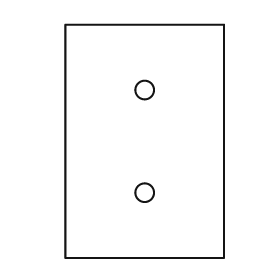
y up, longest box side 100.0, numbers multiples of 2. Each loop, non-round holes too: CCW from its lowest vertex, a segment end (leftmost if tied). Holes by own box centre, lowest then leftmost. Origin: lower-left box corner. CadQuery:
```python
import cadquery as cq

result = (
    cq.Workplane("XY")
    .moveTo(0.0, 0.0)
    .lineTo(68.0, 0.0)
    .lineTo(68.0, 100.0)
    .lineTo(0.0, 100.0)
    .close()
    .moveTo(34.0, 28.0)
    .circle(4.0)
    .moveTo(34.0, 72.0)
    .circle(4.0)
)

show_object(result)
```